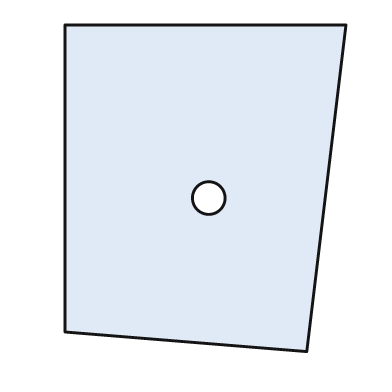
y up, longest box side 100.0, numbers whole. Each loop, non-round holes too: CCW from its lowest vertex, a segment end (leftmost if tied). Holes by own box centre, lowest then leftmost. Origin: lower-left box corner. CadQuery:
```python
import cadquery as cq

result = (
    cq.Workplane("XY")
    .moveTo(74.0, 0.0)
    .lineTo(86.0, 100.0)
    .lineTo(0.0, 100.0)
    .lineTo(0.0, 6.0)
    .close()
    .moveTo(44.0, 47.0)
    .circle(5.0)
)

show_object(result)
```